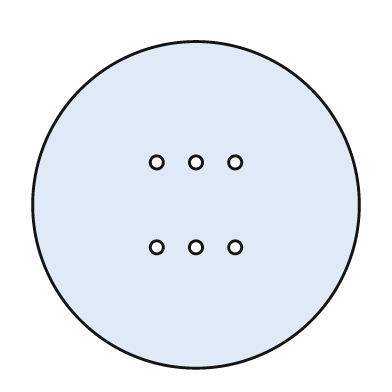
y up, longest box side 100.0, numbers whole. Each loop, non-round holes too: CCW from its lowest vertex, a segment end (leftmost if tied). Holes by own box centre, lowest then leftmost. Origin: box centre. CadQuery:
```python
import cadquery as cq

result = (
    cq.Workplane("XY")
    .moveTo(0.0, 0.0)
    .circle(50.0)
    .moveTo(-12.0, -13.0)
    .circle(2.0)
    .moveTo(0.0, -13.0)
    .circle(2.0)
    .moveTo(12.0, -13.0)
    .circle(2.0)
    .moveTo(-12.0, 13.0)
    .circle(2.0)
    .moveTo(0.0, 13.0)
    .circle(2.0)
    .moveTo(12.0, 13.0)
    .circle(2.0)
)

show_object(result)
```